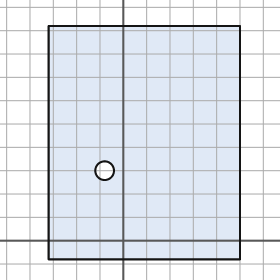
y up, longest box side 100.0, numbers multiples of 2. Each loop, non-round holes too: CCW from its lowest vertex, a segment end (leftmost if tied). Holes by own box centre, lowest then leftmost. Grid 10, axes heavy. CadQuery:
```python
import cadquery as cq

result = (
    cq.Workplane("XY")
    .moveTo(-32.0, -8.0)
    .lineTo(50.0, -8.0)
    .lineTo(50.0, 92.0)
    .lineTo(-32.0, 92.0)
    .close()
    .moveTo(-8.0, 30.0)
    .circle(4.0)
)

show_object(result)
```